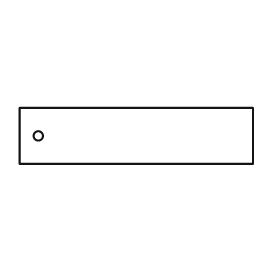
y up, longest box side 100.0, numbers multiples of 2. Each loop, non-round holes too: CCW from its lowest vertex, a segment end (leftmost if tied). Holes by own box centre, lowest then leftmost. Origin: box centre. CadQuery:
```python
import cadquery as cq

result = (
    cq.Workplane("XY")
    .moveTo(-50.0, -12.0)
    .lineTo(50.0, -12.0)
    .lineTo(50.0, 12.0)
    .lineTo(-50.0, 12.0)
    .close()
    .moveTo(-42.0, 0.0)
    .circle(2.0)
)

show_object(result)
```